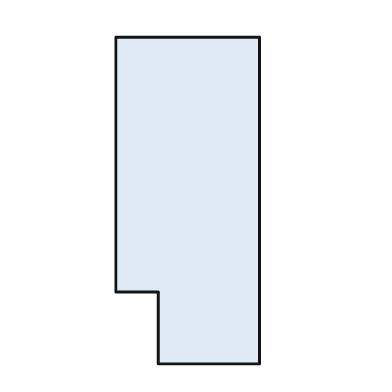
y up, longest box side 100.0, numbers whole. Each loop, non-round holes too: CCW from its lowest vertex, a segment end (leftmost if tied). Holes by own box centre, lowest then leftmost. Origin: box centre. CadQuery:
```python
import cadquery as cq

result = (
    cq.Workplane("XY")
    .moveTo(-9.0, -50.0)
    .lineTo(22.0, -50.0)
    .lineTo(22.0, 50.0)
    .lineTo(-22.0, 50.0)
    .lineTo(-22.0, -28.0)
    .lineTo(-9.0, -28.0)
    .close()
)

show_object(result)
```